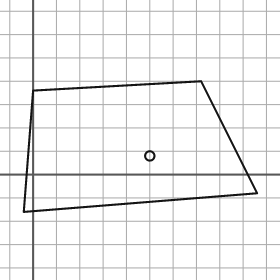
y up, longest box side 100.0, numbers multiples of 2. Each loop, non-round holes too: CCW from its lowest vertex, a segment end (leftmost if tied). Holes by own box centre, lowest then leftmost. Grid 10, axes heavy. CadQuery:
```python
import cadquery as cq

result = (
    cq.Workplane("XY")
    .moveTo(-4.0, -16.0)
    .lineTo(96.0, -8.0)
    .lineTo(72.0, 40.0)
    .lineTo(0.0, 36.0)
    .close()
    .moveTo(50.0, 8.0)
    .circle(2.0)
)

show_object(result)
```